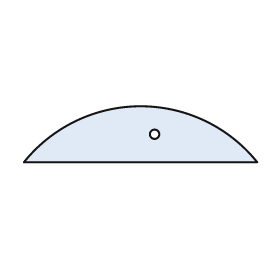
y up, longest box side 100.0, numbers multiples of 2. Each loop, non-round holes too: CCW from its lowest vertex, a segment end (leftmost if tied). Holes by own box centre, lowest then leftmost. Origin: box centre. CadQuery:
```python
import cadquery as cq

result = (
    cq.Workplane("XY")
    .moveTo(-50.0, -12.0)
    .lineTo(50.0, -12.0)
    .threePointArc((0.0, 12.0), (-50.0, -12.0))
    .close()
    .moveTo(6.0, 0.0)
    .circle(2.0)
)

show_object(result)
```